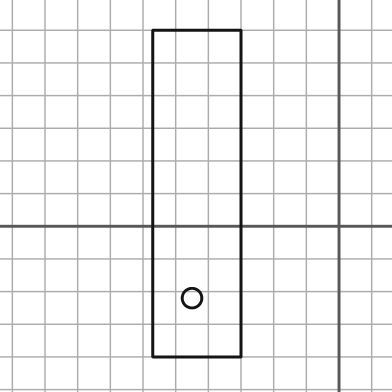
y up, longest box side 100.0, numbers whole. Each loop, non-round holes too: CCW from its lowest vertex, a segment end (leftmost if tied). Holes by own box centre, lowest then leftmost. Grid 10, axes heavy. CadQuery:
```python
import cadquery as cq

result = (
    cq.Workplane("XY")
    .moveTo(-57.0, -40.0)
    .lineTo(-30.0, -40.0)
    .lineTo(-30.0, 60.0)
    .lineTo(-57.0, 60.0)
    .close()
    .moveTo(-45.0, -22.0)
    .circle(3.0)
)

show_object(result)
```